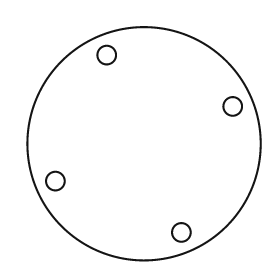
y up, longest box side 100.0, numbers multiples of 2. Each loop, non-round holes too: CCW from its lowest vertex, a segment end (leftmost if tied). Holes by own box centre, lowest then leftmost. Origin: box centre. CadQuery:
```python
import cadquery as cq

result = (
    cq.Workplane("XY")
    .moveTo(0.0, 0.0)
    .circle(50.0)
    .moveTo(16.0, -38.0)
    .circle(4.0)
    .moveTo(-38.0, -16.0)
    .circle(4.0)
    .moveTo(38.0, 16.0)
    .circle(4.0)
    .moveTo(-16.0, 38.0)
    .circle(4.0)
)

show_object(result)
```